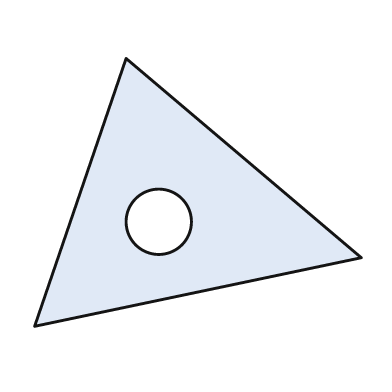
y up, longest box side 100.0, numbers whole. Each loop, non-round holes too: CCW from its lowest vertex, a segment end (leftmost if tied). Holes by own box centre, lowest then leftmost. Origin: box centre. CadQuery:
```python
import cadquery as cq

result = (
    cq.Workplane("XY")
    .moveTo(-50.0, -41.0)
    .lineTo(50.0, -20.0)
    .lineTo(-22.0, 41.0)
    .close()
    .moveTo(-12.0, -9.0)
    .circle(10.0)
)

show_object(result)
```